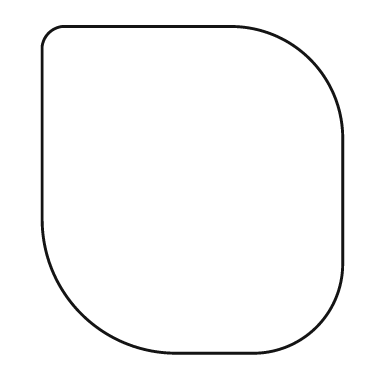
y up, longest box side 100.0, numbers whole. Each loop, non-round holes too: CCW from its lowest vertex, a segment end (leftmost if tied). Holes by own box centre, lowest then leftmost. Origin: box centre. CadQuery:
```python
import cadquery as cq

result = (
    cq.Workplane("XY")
    .moveTo(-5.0, -50.0)
    .lineTo(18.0, -50.0)
    .threePointArc((38.0, -42.0), (46.0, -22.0))
    .lineTo(46.0, 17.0)
    .threePointArc((36.0, 40.0), (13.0, 50.0))
    .lineTo(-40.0, 50.0)
    .threePointArc((-44.0, 48.0), (-46.0, 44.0))
    .lineTo(-46.0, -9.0)
    .threePointArc((-34.0, -38.0), (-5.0, -50.0))
    .close()
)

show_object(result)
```